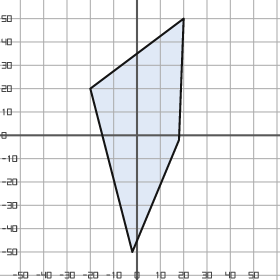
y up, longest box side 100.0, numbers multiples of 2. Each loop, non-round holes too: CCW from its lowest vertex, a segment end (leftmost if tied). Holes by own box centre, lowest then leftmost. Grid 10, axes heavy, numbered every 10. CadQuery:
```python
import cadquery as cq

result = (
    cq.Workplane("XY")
    .moveTo(-2.0, -50.0)
    .lineTo(18.0, -2.0)
    .lineTo(20.0, 50.0)
    .lineTo(-20.0, 20.0)
    .close()
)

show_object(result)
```